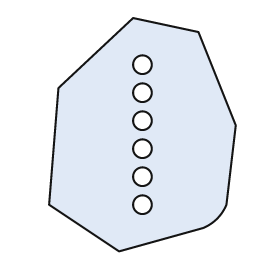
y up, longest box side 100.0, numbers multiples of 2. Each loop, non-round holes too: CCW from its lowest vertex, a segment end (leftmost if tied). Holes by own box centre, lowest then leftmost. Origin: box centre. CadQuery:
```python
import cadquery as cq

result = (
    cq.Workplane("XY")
    .moveTo(-10.0, -50.0)
    .lineTo(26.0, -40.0)
    .threePointArc((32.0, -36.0), (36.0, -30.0))
    .lineTo(40.0, 4.0)
    .lineTo(24.0, 44.0)
    .lineTo(-4.0, 50.0)
    .lineTo(-36.0, 20.0)
    .lineTo(-40.0, -30.0)
    .close()
    .moveTo(0.0, -30.0)
    .circle(4.0)
    .moveTo(0.0, -18.0)
    .circle(4.0)
    .moveTo(0.0, -6.0)
    .circle(4.0)
    .moveTo(0.0, 6.0)
    .circle(4.0)
    .moveTo(0.0, 18.0)
    .circle(4.0)
    .moveTo(0.0, 30.0)
    .circle(4.0)
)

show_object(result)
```